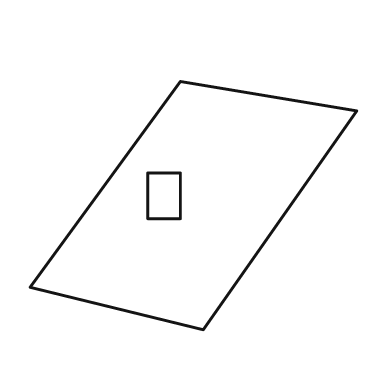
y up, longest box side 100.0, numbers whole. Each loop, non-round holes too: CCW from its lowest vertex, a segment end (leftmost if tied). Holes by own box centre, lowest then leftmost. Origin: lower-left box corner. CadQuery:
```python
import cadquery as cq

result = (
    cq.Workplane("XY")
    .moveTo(53.0, 0.0)
    .lineTo(100.0, 67.0)
    .lineTo(46.0, 76.0)
    .lineTo(0.0, 13.0)
    .close()
    .moveTo(36.0, 34.0)
    .lineTo(46.0, 34.0)
    .lineTo(46.0, 48.0)
    .lineTo(36.0, 48.0)
    .close()
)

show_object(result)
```